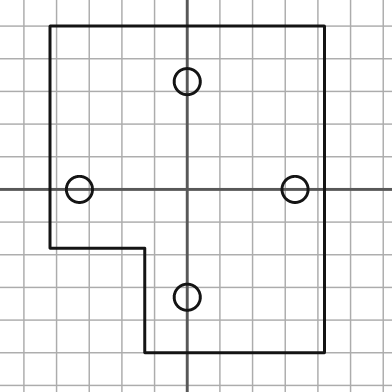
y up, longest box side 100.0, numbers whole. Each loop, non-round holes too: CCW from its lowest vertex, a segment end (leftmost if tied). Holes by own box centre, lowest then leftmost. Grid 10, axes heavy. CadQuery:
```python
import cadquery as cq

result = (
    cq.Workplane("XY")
    .moveTo(-13.0, -50.0)
    .lineTo(42.0, -50.0)
    .lineTo(42.0, 50.0)
    .lineTo(-42.0, 50.0)
    .lineTo(-42.0, -18.0)
    .lineTo(-13.0, -18.0)
    .close()
    .moveTo(0.0, -33.0)
    .circle(4.0)
    .moveTo(-33.0, 0.0)
    .circle(4.0)
    .moveTo(33.0, 0.0)
    .circle(4.0)
    .moveTo(0.0, 33.0)
    .circle(4.0)
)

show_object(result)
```